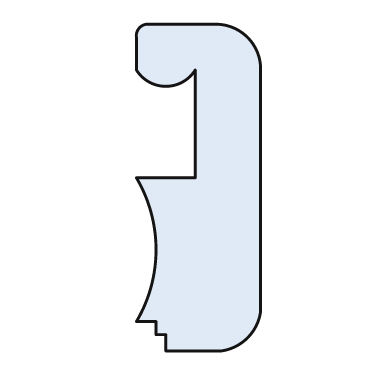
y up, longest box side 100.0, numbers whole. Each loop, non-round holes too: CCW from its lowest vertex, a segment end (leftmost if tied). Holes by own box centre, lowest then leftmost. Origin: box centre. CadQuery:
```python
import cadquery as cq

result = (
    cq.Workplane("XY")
    .moveTo(-10.0, -50.0)
    .lineTo(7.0, -50.0)
    .threePointArc((15.0, -46.0), (19.0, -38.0))
    .lineTo(19.0, 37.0)
    .threePointArc((15.0, 46.0), (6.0, 50.0))
    .lineTo(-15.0, 50.0)
    .threePointArc((-18.0, 49.0), (-19.0, 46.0))
    .lineTo(-19.0, 36.0)
    .threePointArc((-10.0, 31.0), (-1.0, 36.0))
    .lineTo(-1.0, 3.0)
    .lineTo(-19.0, 3.0)
    .threePointArc((-13.0, -19.0), (-19.0, -41.0))
    .lineTo(-13.0, -41.0)
    .lineTo(-13.0, -45.0)
    .lineTo(-10.0, -45.0)
    .close()
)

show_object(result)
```